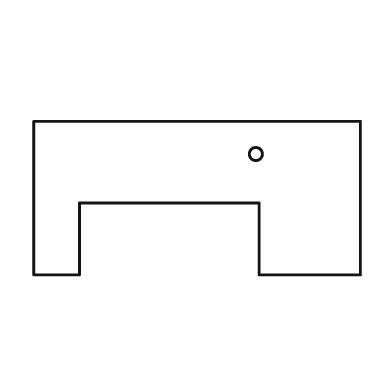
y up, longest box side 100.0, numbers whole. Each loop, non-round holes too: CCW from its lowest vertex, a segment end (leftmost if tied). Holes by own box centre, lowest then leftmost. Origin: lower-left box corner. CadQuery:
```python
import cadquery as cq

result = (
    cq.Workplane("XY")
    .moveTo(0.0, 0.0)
    .lineTo(14.0, 0.0)
    .lineTo(14.0, 22.0)
    .lineTo(69.0, 22.0)
    .lineTo(69.0, 0.0)
    .lineTo(100.0, 0.0)
    .lineTo(100.0, 47.0)
    .lineTo(0.0, 47.0)
    .close()
    .moveTo(68.0, 37.0)
    .circle(2.0)
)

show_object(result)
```